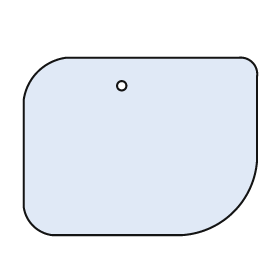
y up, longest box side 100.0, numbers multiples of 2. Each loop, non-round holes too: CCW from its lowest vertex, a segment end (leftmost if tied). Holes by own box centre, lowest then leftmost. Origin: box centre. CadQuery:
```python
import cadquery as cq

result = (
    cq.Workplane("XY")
    .moveTo(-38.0, -38.0)
    .lineTo(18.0, -38.0)
    .threePointArc((40.0, -28.0), (50.0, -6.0))
    .lineTo(50.0, 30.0)
    .threePointArc((48.0, 36.0), (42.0, 38.0))
    .lineTo(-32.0, 38.0)
    .threePointArc((-44.0, 32.0), (-50.0, 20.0))
    .lineTo(-50.0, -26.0)
    .threePointArc((-46.0, -34.0), (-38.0, -38.0))
    .close()
    .moveTo(-8.0, 26.0)
    .circle(2.0)
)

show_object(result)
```